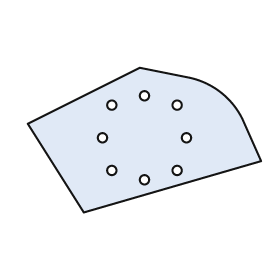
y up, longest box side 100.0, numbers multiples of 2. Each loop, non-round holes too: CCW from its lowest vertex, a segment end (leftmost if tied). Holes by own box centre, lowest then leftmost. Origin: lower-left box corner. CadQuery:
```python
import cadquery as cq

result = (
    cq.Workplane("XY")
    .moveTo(24.0, 0.0)
    .lineTo(100.0, 22.0)
    .lineTo(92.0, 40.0)
    .threePointArc((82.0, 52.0), (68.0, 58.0))
    .lineTo(48.0, 62.0)
    .lineTo(0.0, 38.0)
    .close()
    .moveTo(50.0, 14.0)
    .circle(2.0)
    .moveTo(36.0, 18.0)
    .circle(2.0)
    .moveTo(64.0, 18.0)
    .circle(2.0)
    .moveTo(32.0, 32.0)
    .circle(2.0)
    .moveTo(68.0, 32.0)
    .circle(2.0)
    .moveTo(36.0, 46.0)
    .circle(2.0)
    .moveTo(64.0, 46.0)
    .circle(2.0)
    .moveTo(50.0, 50.0)
    .circle(2.0)
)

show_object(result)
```